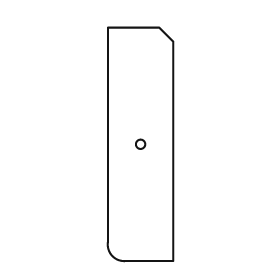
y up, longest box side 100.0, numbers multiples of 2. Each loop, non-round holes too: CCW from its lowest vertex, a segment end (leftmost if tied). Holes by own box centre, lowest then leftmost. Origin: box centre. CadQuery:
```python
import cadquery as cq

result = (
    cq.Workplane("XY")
    .moveTo(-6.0, -50.0)
    .lineTo(14.0, -50.0)
    .lineTo(14.0, 44.0)
    .lineTo(8.0, 50.0)
    .lineTo(-14.0, 50.0)
    .lineTo(-14.0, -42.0)
    .threePointArc((-12.0, -48.0), (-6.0, -50.0))
    .close()
    .moveTo(0.0, 0.0)
    .circle(2.0)
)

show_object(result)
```